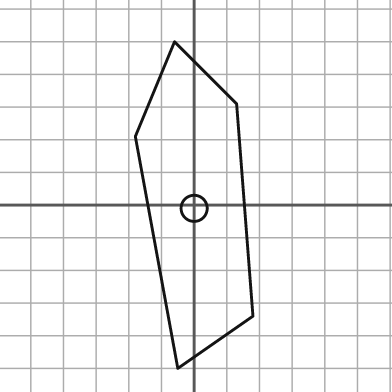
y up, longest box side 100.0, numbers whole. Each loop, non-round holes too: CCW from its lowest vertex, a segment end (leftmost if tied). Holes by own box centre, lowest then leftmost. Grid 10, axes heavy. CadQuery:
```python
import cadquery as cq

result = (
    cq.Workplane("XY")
    .moveTo(-5.0, -50.0)
    .lineTo(18.0, -34.0)
    .lineTo(13.0, 31.0)
    .lineTo(-6.0, 50.0)
    .lineTo(-18.0, 21.0)
    .close()
    .moveTo(0.0, -1.0)
    .circle(4.0)
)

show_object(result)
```